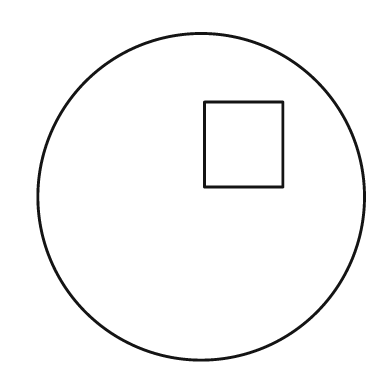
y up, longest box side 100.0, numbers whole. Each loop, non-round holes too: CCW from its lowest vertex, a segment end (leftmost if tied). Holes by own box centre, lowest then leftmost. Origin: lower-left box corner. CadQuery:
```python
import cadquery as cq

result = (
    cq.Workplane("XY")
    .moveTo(50.0, 50.0)
    .circle(50.0)
    .moveTo(51.0, 53.0)
    .lineTo(75.0, 53.0)
    .lineTo(75.0, 79.0)
    .lineTo(51.0, 79.0)
    .close()
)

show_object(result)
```